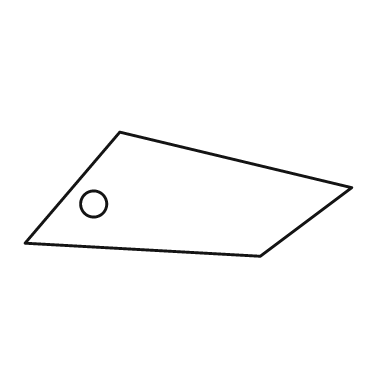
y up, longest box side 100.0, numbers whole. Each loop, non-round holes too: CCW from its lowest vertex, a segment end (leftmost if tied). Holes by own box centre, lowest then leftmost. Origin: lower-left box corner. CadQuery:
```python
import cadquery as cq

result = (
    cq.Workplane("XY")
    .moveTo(72.0, 0.0)
    .lineTo(100.0, 21.0)
    .lineTo(29.0, 38.0)
    .lineTo(0.0, 4.0)
    .close()
    .moveTo(21.0, 16.0)
    .circle(4.0)
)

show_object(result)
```